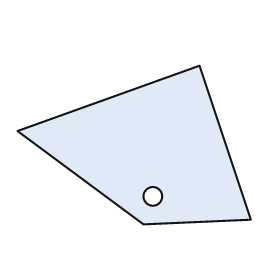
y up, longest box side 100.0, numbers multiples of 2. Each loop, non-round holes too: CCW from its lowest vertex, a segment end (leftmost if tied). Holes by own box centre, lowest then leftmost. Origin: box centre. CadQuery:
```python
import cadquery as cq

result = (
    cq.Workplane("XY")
    .moveTo(4.0, -34.0)
    .lineTo(50.0, -32.0)
    .lineTo(28.0, 34.0)
    .lineTo(-50.0, 6.0)
    .close()
    .moveTo(8.0, -22.0)
    .circle(4.0)
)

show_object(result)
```